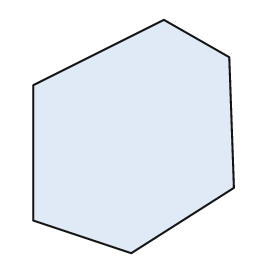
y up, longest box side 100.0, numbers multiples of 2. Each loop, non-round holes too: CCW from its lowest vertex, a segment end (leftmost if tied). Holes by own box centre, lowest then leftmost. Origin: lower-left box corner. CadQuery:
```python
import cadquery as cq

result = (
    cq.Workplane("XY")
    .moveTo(42.0, 0.0)
    .lineTo(86.0, 28.0)
    .lineTo(84.0, 84.0)
    .lineTo(56.0, 100.0)
    .lineTo(0.0, 72.0)
    .lineTo(0.0, 14.0)
    .close()
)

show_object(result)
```